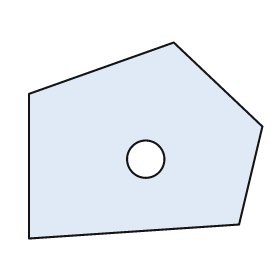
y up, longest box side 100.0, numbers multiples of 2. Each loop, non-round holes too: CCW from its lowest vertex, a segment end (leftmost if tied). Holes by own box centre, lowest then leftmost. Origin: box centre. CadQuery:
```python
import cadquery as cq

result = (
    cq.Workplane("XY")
    .moveTo(-50.0, -42.0)
    .lineTo(40.0, -36.0)
    .lineTo(50.0, 6.0)
    .lineTo(12.0, 42.0)
    .lineTo(-50.0, 20.0)
    .close()
    .moveTo(0.0, -8.0)
    .circle(8.0)
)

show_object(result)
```